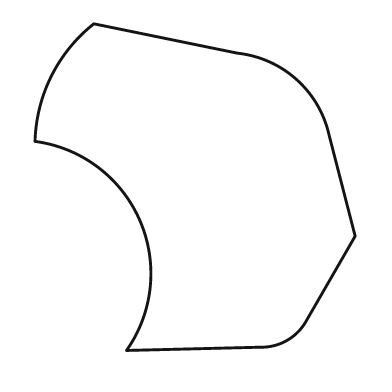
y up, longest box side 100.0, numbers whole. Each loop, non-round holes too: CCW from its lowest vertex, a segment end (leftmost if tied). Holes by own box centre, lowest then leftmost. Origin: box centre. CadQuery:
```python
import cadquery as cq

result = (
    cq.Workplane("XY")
    .moveTo(-21.0, -50.0)
    .lineTo(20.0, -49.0)
    .threePointArc((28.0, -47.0), (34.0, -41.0))
    .lineTo(49.0, -15.0)
    .lineTo(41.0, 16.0)
    .threePointArc((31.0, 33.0), (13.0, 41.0))
    .lineTo(-31.0, 50.0)
    .threePointArc((-44.0, 34.0), (-49.0, 14.0))
    .threePointArc((-17.0, -10.0), (-21.0, -50.0))
    .close()
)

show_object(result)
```